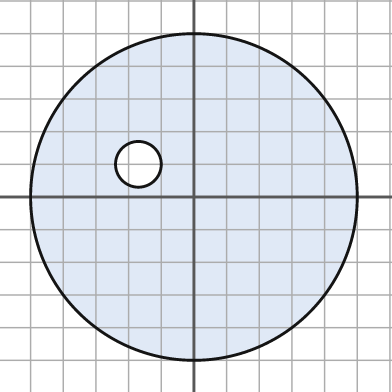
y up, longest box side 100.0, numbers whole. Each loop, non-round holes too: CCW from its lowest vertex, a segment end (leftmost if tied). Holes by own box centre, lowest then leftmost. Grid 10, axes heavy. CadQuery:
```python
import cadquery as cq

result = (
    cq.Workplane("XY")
    .moveTo(0.0, 0.0)
    .circle(50.0)
    .moveTo(-17.0, 10.0)
    .circle(7.0)
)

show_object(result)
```